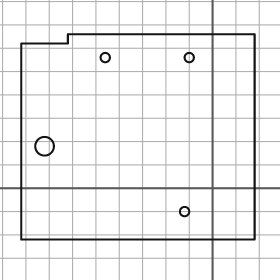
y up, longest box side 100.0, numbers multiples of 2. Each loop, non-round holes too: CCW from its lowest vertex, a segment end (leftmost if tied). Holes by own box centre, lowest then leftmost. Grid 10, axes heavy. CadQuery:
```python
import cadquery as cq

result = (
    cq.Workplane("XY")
    .moveTo(-82.0, -22.0)
    .lineTo(18.0, -22.0)
    .lineTo(18.0, 66.0)
    .lineTo(-62.0, 66.0)
    .lineTo(-62.0, 62.0)
    .lineTo(-82.0, 62.0)
    .close()
    .moveTo(-12.0, -10.0)
    .circle(2.0)
    .moveTo(-72.0, 18.0)
    .circle(4.0)
    .moveTo(-46.0, 56.0)
    .circle(2.0)
    .moveTo(-10.0, 56.0)
    .circle(2.0)
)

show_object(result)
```